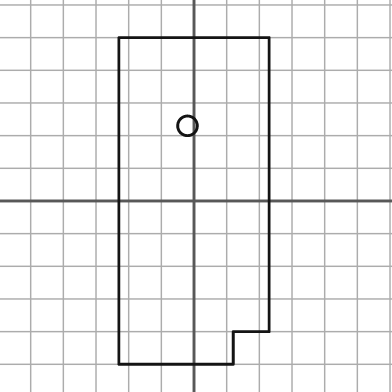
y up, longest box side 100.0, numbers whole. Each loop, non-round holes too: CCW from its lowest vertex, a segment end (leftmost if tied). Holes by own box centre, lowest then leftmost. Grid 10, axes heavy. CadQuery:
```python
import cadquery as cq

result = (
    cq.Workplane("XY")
    .moveTo(-23.0, -50.0)
    .lineTo(12.0, -50.0)
    .lineTo(12.0, -40.0)
    .lineTo(23.0, -40.0)
    .lineTo(23.0, 50.0)
    .lineTo(-23.0, 50.0)
    .close()
    .moveTo(-2.0, 23.0)
    .circle(3.0)
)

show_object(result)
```